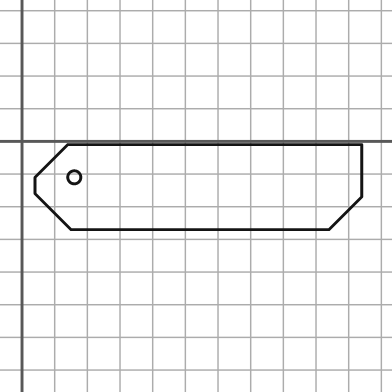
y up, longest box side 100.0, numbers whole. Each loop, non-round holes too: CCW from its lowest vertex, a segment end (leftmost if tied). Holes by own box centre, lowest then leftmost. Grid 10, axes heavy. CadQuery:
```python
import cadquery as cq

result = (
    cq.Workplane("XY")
    .moveTo(15.0, -27.0)
    .lineTo(94.0, -27.0)
    .lineTo(104.0, -17.0)
    .lineTo(104.0, -1.0)
    .lineTo(14.0, -1.0)
    .lineTo(4.0, -11.0)
    .lineTo(4.0, -16.0)
    .close()
    .moveTo(16.0, -11.0)
    .circle(2.0)
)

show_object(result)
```